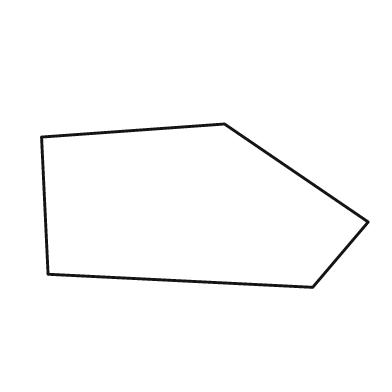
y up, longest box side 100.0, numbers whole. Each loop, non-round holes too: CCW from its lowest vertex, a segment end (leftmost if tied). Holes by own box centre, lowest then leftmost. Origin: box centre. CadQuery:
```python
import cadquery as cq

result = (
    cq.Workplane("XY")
    .moveTo(33.0, -25.0)
    .lineTo(50.0, -5.0)
    .lineTo(6.0, 25.0)
    .lineTo(-50.0, 21.0)
    .lineTo(-48.0, -21.0)
    .close()
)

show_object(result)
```